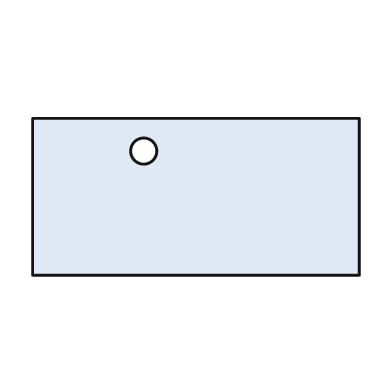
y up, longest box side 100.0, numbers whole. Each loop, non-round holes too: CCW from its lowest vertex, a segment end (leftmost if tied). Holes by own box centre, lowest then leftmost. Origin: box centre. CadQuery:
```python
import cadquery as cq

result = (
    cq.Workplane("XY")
    .moveTo(-50.0, -24.0)
    .lineTo(50.0, -24.0)
    .lineTo(50.0, 24.0)
    .lineTo(-50.0, 24.0)
    .close()
    .moveTo(-16.0, 14.0)
    .circle(4.0)
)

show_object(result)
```